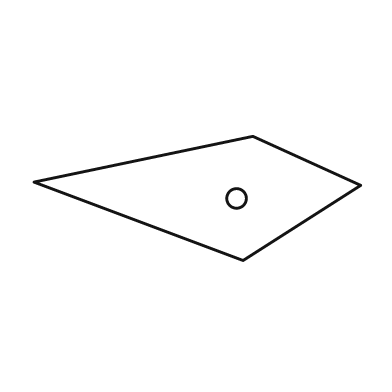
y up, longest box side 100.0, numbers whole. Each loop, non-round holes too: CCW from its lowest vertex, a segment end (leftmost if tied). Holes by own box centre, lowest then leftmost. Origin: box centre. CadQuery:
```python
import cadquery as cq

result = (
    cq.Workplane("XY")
    .moveTo(14.0, -19.0)
    .lineTo(50.0, 4.0)
    .lineTo(17.0, 19.0)
    .lineTo(-50.0, 5.0)
    .close()
    .moveTo(12.0, 0.0)
    .circle(3.0)
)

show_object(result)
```